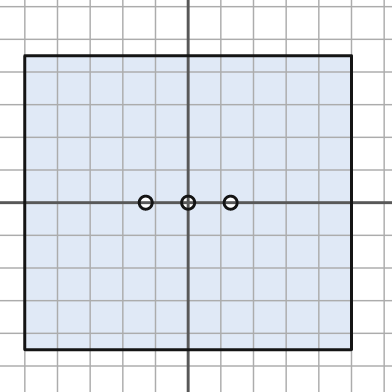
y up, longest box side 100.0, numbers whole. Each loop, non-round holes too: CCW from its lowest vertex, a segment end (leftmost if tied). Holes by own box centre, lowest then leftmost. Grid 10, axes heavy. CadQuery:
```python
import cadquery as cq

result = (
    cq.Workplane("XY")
    .moveTo(-50.0, -45.0)
    .lineTo(50.0, -45.0)
    .lineTo(50.0, 45.0)
    .lineTo(-50.0, 45.0)
    .close()
    .moveTo(-13.0, 0.0)
    .circle(2.0)
    .moveTo(0.0, 0.0)
    .circle(2.0)
    .moveTo(13.0, 0.0)
    .circle(2.0)
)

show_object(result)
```